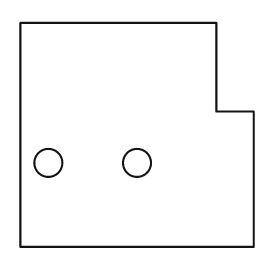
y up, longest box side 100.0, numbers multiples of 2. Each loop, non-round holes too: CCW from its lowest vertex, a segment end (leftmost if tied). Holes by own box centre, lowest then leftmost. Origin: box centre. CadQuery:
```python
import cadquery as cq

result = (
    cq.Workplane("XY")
    .moveTo(-50.0, -48.0)
    .lineTo(50.0, -48.0)
    .lineTo(50.0, 10.0)
    .lineTo(34.0, 10.0)
    .lineTo(34.0, 48.0)
    .lineTo(-50.0, 48.0)
    .close()
    .moveTo(-38.0, -12.0)
    .circle(6.0)
    .moveTo(0.0, -12.0)
    .circle(6.0)
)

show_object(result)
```